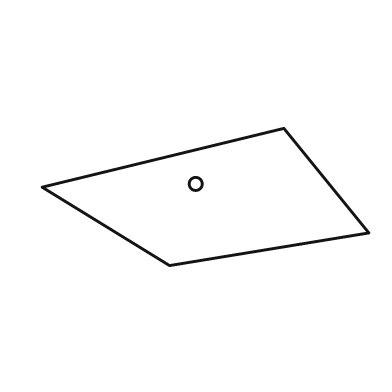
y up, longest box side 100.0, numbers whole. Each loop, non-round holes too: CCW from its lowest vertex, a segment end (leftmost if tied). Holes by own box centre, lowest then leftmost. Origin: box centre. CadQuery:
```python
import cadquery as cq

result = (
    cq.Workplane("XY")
    .moveTo(-11.0, -21.0)
    .lineTo(50.0, -11.0)
    .lineTo(24.0, 21.0)
    .lineTo(-50.0, 3.0)
    .close()
    .moveTo(-3.0, 4.0)
    .circle(2.0)
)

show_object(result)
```